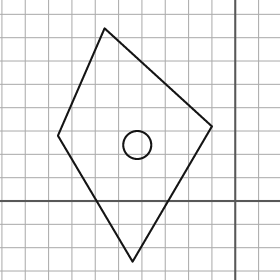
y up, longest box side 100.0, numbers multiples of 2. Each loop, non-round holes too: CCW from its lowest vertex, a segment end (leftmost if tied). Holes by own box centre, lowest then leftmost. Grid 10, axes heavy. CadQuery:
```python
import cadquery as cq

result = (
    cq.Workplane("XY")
    .moveTo(-44.0, -26.0)
    .lineTo(-10.0, 32.0)
    .lineTo(-56.0, 74.0)
    .lineTo(-76.0, 28.0)
    .close()
    .moveTo(-42.0, 24.0)
    .circle(6.0)
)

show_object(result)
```